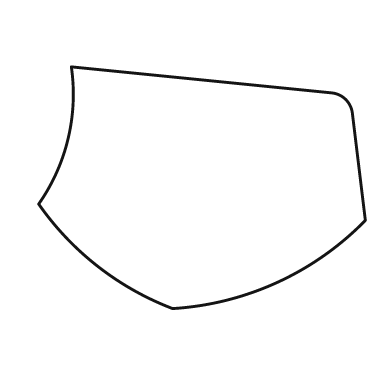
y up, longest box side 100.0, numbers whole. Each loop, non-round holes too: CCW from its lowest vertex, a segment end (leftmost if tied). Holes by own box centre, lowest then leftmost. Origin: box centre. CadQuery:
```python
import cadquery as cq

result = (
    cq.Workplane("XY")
    .moveTo(-9.0, -37.0)
    .threePointArc((23.0, -29.0), (50.0, -10.0))
    .lineTo(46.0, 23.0)
    .threePointArc((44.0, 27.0), (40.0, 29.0))
    .lineTo(-40.0, 37.0)
    .threePointArc((-41.0, 15.0), (-50.0, -5.0))
    .threePointArc((-32.0, -24.0), (-9.0, -37.0))
    .close()
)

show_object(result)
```